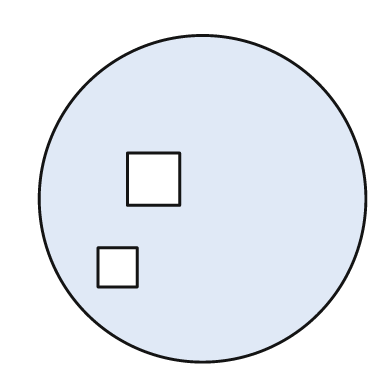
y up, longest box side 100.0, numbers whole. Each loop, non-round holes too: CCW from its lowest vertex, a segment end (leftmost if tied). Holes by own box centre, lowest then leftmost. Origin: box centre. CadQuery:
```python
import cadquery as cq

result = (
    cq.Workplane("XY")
    .moveTo(0.0, 0.0)
    .circle(50.0)
    .moveTo(-32.0, -27.0)
    .lineTo(-20.0, -27.0)
    .lineTo(-20.0, -15.0)
    .lineTo(-32.0, -15.0)
    .close()
    .moveTo(-23.0, -2.0)
    .lineTo(-7.0, -2.0)
    .lineTo(-7.0, 14.0)
    .lineTo(-23.0, 14.0)
    .close()
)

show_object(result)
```